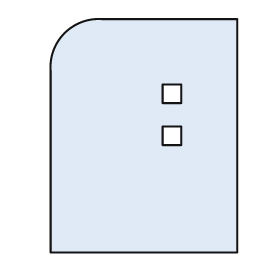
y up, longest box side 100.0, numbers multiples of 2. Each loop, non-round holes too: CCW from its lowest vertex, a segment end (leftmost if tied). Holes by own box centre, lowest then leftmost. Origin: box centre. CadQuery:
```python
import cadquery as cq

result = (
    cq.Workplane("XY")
    .moveTo(-40.0, -50.0)
    .lineTo(40.0, -50.0)
    .lineTo(40.0, 50.0)
    .lineTo(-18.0, 50.0)
    .threePointArc((-34.0, 44.0), (-40.0, 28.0))
    .close()
    .moveTo(8.0, -4.0)
    .lineTo(16.0, -4.0)
    .lineTo(16.0, 4.0)
    .lineTo(8.0, 4.0)
    .close()
    .moveTo(8.0, 14.0)
    .lineTo(16.0, 14.0)
    .lineTo(16.0, 22.0)
    .lineTo(8.0, 22.0)
    .close()
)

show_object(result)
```